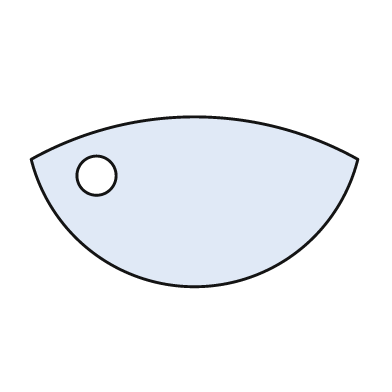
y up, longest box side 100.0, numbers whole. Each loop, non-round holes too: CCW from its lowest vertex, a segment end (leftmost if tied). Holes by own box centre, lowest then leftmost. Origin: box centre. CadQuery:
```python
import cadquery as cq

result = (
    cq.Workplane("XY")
    .moveTo(-50.0, 13.0)
    .threePointArc((0.0, -26.0), (50.0, 13.0))
    .threePointArc((0.0, 26.0), (-50.0, 13.0))
    .close()
    .moveTo(-30.0, 8.0)
    .circle(6.0)
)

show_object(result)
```